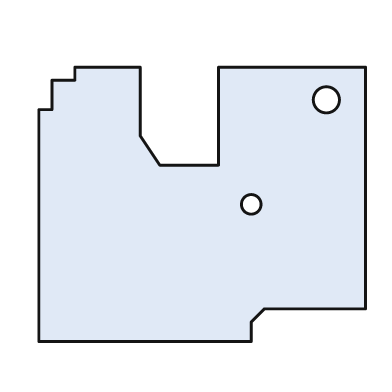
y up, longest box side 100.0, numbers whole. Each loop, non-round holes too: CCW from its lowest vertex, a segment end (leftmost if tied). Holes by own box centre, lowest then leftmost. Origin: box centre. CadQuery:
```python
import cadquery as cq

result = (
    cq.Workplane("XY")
    .moveTo(-50.0, -42.0)
    .lineTo(15.0, -42.0)
    .lineTo(15.0, -36.0)
    .lineTo(19.0, -32.0)
    .lineTo(50.0, -32.0)
    .lineTo(50.0, 42.0)
    .lineTo(5.0, 42.0)
    .lineTo(5.0, 12.0)
    .lineTo(-13.0, 12.0)
    .lineTo(-19.0, 21.0)
    .lineTo(-19.0, 42.0)
    .lineTo(-39.0, 42.0)
    .lineTo(-39.0, 38.0)
    .lineTo(-46.0, 38.0)
    .lineTo(-46.0, 29.0)
    .lineTo(-50.0, 29.0)
    .close()
    .moveTo(15.0, 0.0)
    .circle(3.0)
    .moveTo(38.0, 32.0)
    .circle(4.0)
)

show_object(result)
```